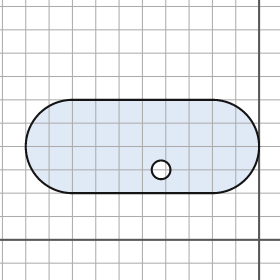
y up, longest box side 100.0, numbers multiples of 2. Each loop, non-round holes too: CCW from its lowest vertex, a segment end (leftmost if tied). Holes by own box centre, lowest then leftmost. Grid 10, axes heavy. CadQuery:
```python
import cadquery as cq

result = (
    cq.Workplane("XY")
    .moveTo(-80.0, 20.0)
    .lineTo(-20.0, 20.0)
    .threePointArc((0.0, 40.0), (-20.0, 60.0))
    .lineTo(-80.0, 60.0)
    .threePointArc((-100.0, 40.0), (-80.0, 20.0))
    .close()
    .moveTo(-42.0, 30.0)
    .circle(4.0)
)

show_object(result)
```